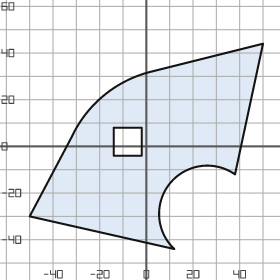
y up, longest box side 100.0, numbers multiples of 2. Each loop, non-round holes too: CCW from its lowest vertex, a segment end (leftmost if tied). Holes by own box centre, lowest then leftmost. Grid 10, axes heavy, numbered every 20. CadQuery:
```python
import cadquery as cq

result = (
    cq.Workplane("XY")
    .moveTo(12.0, -44.0)
    .threePointArc((10.0, -16.0), (38.0, -12.0))
    .lineTo(50.0, 44.0)
    .lineTo(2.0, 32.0)
    .threePointArc((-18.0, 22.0), (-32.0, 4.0))
    .lineTo(-50.0, -30.0)
    .close()
    .moveTo(-14.0, -4.0)
    .lineTo(-2.0, -4.0)
    .lineTo(-2.0, 8.0)
    .lineTo(-14.0, 8.0)
    .close()
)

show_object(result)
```